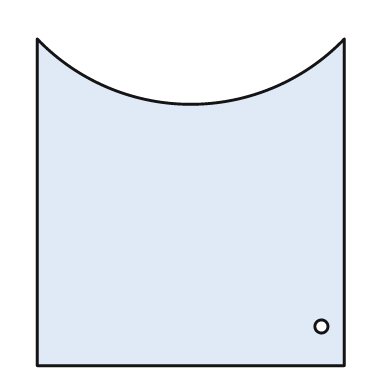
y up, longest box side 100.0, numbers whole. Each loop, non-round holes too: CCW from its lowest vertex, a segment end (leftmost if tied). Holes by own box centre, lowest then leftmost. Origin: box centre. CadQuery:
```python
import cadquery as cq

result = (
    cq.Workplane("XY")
    .moveTo(-47.0, -50.0)
    .lineTo(47.0, -50.0)
    .lineTo(47.0, 50.0)
    .threePointArc((0.0, 30.0), (-47.0, 50.0))
    .close()
    .moveTo(40.0, -38.0)
    .circle(2.0)
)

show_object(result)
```